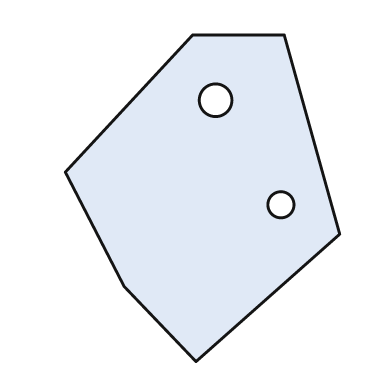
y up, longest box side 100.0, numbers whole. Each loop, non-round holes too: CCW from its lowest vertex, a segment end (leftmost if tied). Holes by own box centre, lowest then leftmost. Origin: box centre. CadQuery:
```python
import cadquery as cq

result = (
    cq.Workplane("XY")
    .moveTo(-2.0, -50.0)
    .lineTo(42.0, -11.0)
    .lineTo(25.0, 50.0)
    .lineTo(-3.0, 50.0)
    .lineTo(-42.0, 8.0)
    .lineTo(-24.0, -27.0)
    .close()
    .moveTo(24.0, -2.0)
    .circle(4.0)
    .moveTo(4.0, 30.0)
    .circle(5.0)
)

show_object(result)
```